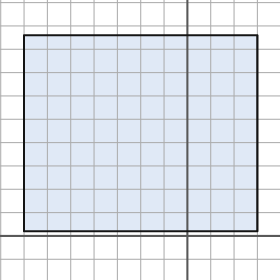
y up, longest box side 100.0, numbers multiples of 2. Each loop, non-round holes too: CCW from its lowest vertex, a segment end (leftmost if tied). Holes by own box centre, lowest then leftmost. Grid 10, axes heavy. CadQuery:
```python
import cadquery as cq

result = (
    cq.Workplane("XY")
    .moveTo(-70.0, 2.0)
    .lineTo(30.0, 2.0)
    .lineTo(30.0, 86.0)
    .lineTo(-70.0, 86.0)
    .close()
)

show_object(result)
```